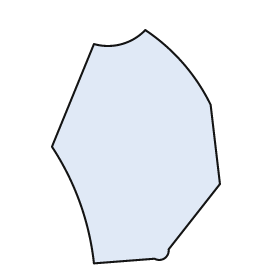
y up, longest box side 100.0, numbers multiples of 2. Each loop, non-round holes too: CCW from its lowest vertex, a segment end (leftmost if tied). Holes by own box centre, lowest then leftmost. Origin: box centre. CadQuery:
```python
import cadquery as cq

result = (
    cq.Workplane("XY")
    .moveTo(-18.0, -50.0)
    .lineTo(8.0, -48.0)
    .threePointArc((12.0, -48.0), (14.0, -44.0))
    .lineTo(36.0, -16.0)
    .lineTo(32.0, 18.0)
    .threePointArc((20.0, 36.0), (4.0, 50.0))
    .threePointArc((-6.0, 44.0), (-18.0, 44.0))
    .lineTo(-36.0, 0.0)
    .threePointArc((-24.0, -24.0), (-18.0, -50.0))
    .close()
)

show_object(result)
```